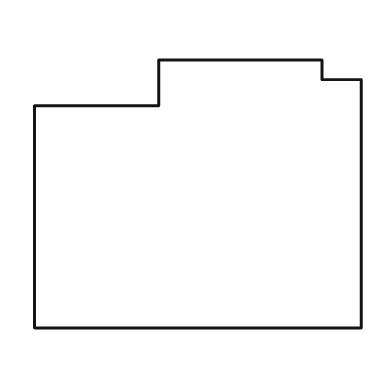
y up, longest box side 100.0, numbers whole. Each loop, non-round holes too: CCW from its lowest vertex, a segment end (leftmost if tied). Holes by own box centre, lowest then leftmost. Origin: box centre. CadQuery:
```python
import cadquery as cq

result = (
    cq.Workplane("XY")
    .moveTo(-50.0, -41.0)
    .lineTo(50.0, -41.0)
    .lineTo(50.0, 35.0)
    .lineTo(38.0, 35.0)
    .lineTo(38.0, 41.0)
    .lineTo(-12.0, 41.0)
    .lineTo(-12.0, 27.0)
    .lineTo(-50.0, 27.0)
    .close()
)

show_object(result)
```